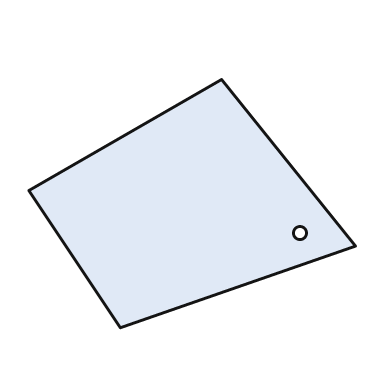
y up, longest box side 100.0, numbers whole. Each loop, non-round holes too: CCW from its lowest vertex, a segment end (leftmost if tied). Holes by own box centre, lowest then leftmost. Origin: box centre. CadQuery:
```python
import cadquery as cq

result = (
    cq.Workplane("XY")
    .moveTo(-22.0, -38.0)
    .lineTo(50.0, -13.0)
    .lineTo(9.0, 38.0)
    .lineTo(-50.0, 4.0)
    .close()
    .moveTo(33.0, -9.0)
    .circle(2.0)
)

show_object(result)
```